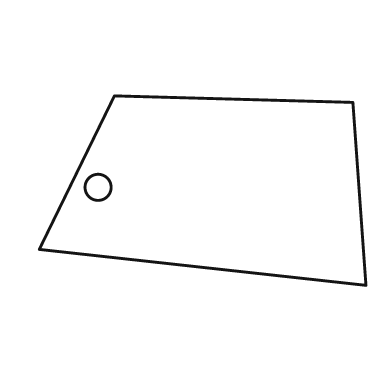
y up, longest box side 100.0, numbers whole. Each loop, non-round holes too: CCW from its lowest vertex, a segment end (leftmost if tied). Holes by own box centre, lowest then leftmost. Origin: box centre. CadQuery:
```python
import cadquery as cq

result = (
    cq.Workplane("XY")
    .moveTo(50.0, -29.0)
    .lineTo(46.0, 27.0)
    .lineTo(-27.0, 29.0)
    .lineTo(-50.0, -18.0)
    .close()
    .moveTo(-32.0, 1.0)
    .circle(4.0)
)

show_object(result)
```